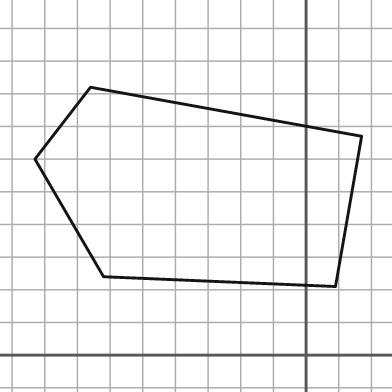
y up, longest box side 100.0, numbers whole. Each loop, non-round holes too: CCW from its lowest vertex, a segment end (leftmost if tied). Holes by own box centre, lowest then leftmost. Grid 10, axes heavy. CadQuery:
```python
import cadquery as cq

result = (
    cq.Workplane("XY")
    .moveTo(9.0, 21.0)
    .lineTo(17.0, 67.0)
    .lineTo(-66.0, 82.0)
    .lineTo(-83.0, 60.0)
    .lineTo(-62.0, 24.0)
    .close()
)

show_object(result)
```